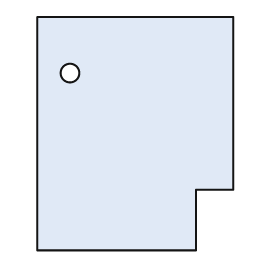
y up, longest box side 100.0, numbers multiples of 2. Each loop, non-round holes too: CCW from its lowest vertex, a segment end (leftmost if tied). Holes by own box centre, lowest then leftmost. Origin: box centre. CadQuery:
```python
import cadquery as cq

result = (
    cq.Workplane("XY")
    .moveTo(-42.0, -50.0)
    .lineTo(26.0, -50.0)
    .lineTo(26.0, -24.0)
    .lineTo(42.0, -24.0)
    .lineTo(42.0, 50.0)
    .lineTo(-42.0, 50.0)
    .close()
    .moveTo(-28.0, 26.0)
    .circle(4.0)
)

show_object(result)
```